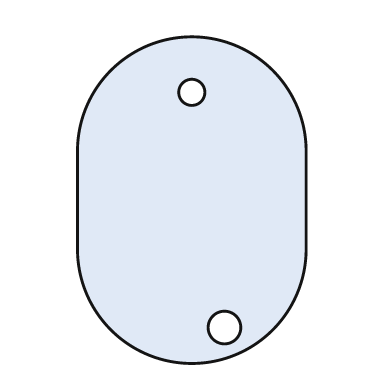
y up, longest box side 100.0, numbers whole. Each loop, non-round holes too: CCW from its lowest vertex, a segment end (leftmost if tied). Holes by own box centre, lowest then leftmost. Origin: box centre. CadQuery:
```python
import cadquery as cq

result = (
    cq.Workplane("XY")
    .moveTo(-35.0, -15.0)
    .threePointArc((0.0, -50.0), (35.0, -15.0))
    .lineTo(35.0, 15.0)
    .threePointArc((0.0, 50.0), (-35.0, 15.0))
    .close()
    .moveTo(10.0, -39.0)
    .circle(5.0)
    .moveTo(0.0, 33.0)
    .circle(4.0)
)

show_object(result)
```